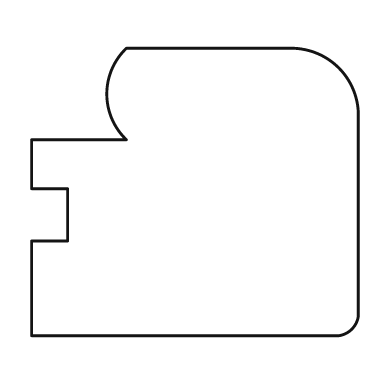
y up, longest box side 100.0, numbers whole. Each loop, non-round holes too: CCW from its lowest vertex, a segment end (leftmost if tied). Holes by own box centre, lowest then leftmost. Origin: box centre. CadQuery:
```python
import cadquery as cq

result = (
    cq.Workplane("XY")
    .moveTo(-50.0, -44.0)
    .lineTo(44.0, -44.0)
    .threePointArc((48.0, -42.0), (50.0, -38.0))
    .lineTo(50.0, 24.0)
    .threePointArc((44.0, 38.0), (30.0, 44.0))
    .lineTo(-21.0, 44.0)
    .threePointArc((-27.0, 30.0), (-21.0, 16.0))
    .lineTo(-50.0, 16.0)
    .lineTo(-50.0, 1.0)
    .lineTo(-39.0, 1.0)
    .lineTo(-39.0, -15.0)
    .lineTo(-50.0, -15.0)
    .close()
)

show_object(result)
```